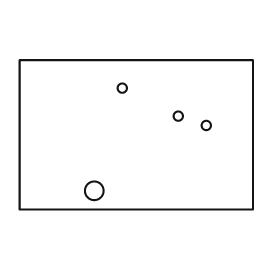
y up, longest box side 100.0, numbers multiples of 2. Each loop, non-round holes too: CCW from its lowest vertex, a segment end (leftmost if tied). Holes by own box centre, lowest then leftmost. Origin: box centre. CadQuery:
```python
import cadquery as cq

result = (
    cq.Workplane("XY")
    .moveTo(-50.0, -32.0)
    .lineTo(50.0, -32.0)
    .lineTo(50.0, 32.0)
    .lineTo(-50.0, 32.0)
    .close()
    .moveTo(-18.0, -24.0)
    .circle(4.0)
    .moveTo(30.0, 4.0)
    .circle(2.0)
    .moveTo(18.0, 8.0)
    .circle(2.0)
    .moveTo(-6.0, 20.0)
    .circle(2.0)
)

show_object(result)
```